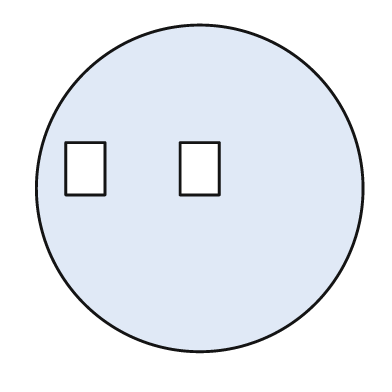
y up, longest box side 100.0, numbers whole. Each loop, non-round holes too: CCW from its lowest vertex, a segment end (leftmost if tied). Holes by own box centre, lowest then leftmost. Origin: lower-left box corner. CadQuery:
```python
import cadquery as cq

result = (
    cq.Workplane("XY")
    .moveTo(50.0, 50.0)
    .circle(50.0)
    .moveTo(9.0, 48.0)
    .lineTo(21.0, 48.0)
    .lineTo(21.0, 64.0)
    .lineTo(9.0, 64.0)
    .close()
    .moveTo(44.0, 48.0)
    .lineTo(56.0, 48.0)
    .lineTo(56.0, 64.0)
    .lineTo(44.0, 64.0)
    .close()
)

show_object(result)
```